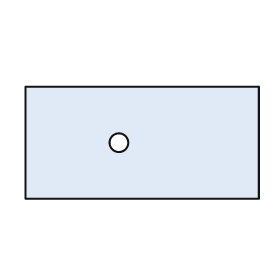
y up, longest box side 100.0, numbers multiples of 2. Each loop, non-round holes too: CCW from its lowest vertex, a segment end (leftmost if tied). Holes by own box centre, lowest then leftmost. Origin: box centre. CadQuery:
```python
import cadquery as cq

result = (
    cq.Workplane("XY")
    .moveTo(-50.0, -24.0)
    .lineTo(50.0, -24.0)
    .lineTo(50.0, 24.0)
    .lineTo(-50.0, 24.0)
    .close()
    .moveTo(-10.0, 0.0)
    .circle(4.0)
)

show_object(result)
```